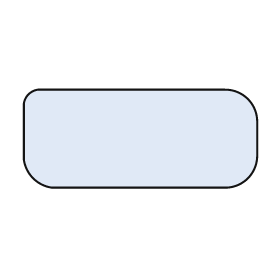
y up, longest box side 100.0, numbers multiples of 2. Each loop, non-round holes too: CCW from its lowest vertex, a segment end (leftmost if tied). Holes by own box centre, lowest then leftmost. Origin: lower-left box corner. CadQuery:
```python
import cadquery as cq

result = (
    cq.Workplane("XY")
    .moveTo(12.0, 0.0)
    .lineTo(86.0, 0.0)
    .threePointArc((96.0, 4.0), (100.0, 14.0))
    .lineTo(100.0, 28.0)
    .threePointArc((96.0, 38.0), (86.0, 42.0))
    .lineTo(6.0, 42.0)
    .threePointArc((2.0, 40.0), (0.0, 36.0))
    .lineTo(0.0, 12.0)
    .threePointArc((4.0, 4.0), (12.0, 0.0))
    .close()
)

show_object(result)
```